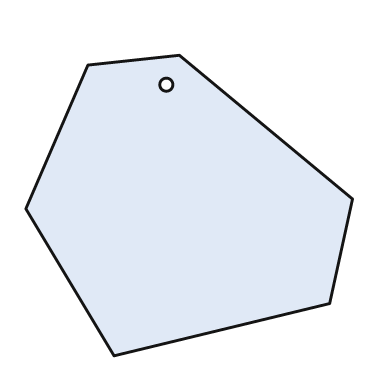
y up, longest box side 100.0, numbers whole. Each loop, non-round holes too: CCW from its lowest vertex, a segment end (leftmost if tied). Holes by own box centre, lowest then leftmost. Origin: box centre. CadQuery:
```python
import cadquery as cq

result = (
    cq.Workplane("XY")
    .moveTo(-23.0, -46.0)
    .lineTo(43.0, -30.0)
    .lineTo(50.0, 2.0)
    .lineTo(-3.0, 46.0)
    .lineTo(-31.0, 43.0)
    .lineTo(-50.0, -1.0)
    .close()
    .moveTo(-7.0, 37.0)
    .circle(2.0)
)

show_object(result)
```